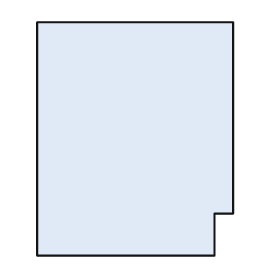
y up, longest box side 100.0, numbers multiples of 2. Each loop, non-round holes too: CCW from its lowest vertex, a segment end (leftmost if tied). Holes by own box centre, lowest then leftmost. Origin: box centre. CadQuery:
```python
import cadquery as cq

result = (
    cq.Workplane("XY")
    .moveTo(-42.0, -50.0)
    .lineTo(34.0, -50.0)
    .lineTo(34.0, -32.0)
    .lineTo(42.0, -32.0)
    .lineTo(42.0, 50.0)
    .lineTo(-42.0, 50.0)
    .close()
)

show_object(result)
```